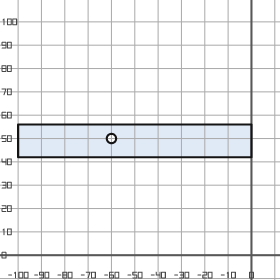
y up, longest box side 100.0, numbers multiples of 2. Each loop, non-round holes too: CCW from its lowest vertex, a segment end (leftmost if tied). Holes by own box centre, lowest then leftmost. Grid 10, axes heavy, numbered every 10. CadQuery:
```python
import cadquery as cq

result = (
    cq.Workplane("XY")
    .moveTo(-100.0, 42.0)
    .lineTo(0.0, 42.0)
    .lineTo(0.0, 56.0)
    .lineTo(-100.0, 56.0)
    .close()
    .moveTo(-60.0, 50.0)
    .circle(2.0)
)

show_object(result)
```